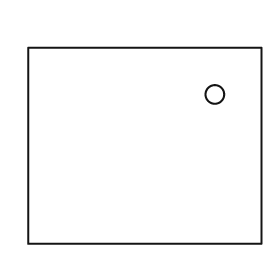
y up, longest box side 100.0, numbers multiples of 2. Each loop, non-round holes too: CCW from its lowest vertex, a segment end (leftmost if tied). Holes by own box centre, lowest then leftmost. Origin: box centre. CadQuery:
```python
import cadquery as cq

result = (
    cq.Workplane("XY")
    .moveTo(-50.0, -42.0)
    .lineTo(50.0, -42.0)
    .lineTo(50.0, 42.0)
    .lineTo(-50.0, 42.0)
    .close()
    .moveTo(30.0, 22.0)
    .circle(4.0)
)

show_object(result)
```